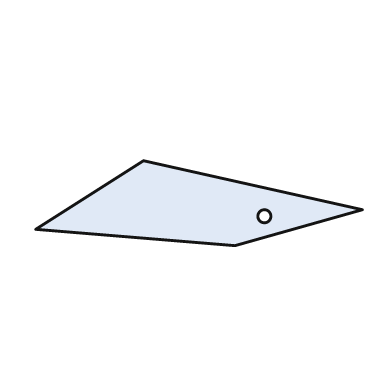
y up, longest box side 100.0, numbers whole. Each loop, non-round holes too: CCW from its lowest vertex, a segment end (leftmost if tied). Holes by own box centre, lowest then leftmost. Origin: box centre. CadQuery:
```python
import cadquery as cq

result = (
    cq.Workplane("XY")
    .moveTo(11.0, -13.0)
    .lineTo(50.0, -2.0)
    .lineTo(-17.0, 13.0)
    .lineTo(-50.0, -8.0)
    .close()
    .moveTo(20.0, -4.0)
    .circle(2.0)
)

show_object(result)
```